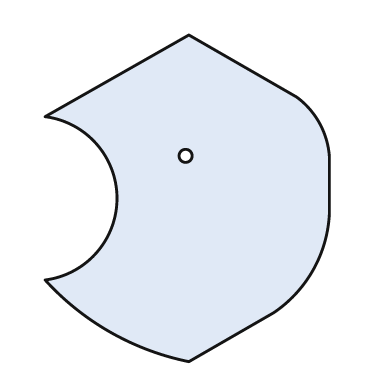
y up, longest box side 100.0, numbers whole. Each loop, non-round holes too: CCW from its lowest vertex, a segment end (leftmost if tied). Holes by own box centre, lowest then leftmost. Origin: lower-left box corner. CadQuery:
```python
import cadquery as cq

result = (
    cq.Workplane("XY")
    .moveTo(44.0, 0.0)
    .lineTo(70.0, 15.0)
    .threePointArc((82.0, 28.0), (87.0, 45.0))
    .lineTo(87.0, 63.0)
    .threePointArc((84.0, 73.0), (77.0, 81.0))
    .lineTo(44.0, 100.0)
    .lineTo(0.0, 75.0)
    .threePointArc((22.0, 50.0), (0.0, 25.0))
    .threePointArc((20.0, 9.0), (44.0, 0.0))
    .close()
    .moveTo(43.0, 63.0)
    .circle(2.0)
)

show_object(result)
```